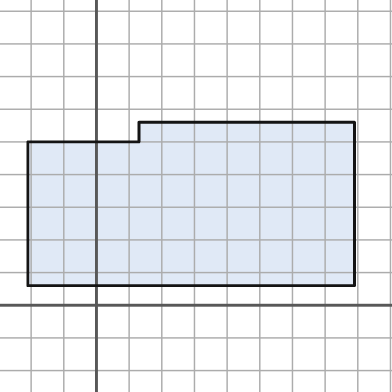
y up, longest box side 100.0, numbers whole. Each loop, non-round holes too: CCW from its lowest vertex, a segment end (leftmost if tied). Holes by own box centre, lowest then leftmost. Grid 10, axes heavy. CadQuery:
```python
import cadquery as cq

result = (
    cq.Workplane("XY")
    .moveTo(-21.0, 6.0)
    .lineTo(79.0, 6.0)
    .lineTo(79.0, 56.0)
    .lineTo(13.0, 56.0)
    .lineTo(13.0, 50.0)
    .lineTo(-21.0, 50.0)
    .close()
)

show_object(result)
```